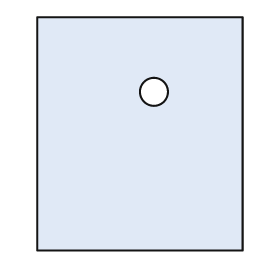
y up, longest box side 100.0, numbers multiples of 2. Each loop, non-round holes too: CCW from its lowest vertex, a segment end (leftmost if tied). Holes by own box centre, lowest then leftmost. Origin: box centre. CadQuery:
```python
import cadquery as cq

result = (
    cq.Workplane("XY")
    .moveTo(-44.0, -50.0)
    .lineTo(44.0, -50.0)
    .lineTo(44.0, 50.0)
    .lineTo(-44.0, 50.0)
    .close()
    .moveTo(6.0, 18.0)
    .circle(6.0)
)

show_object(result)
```